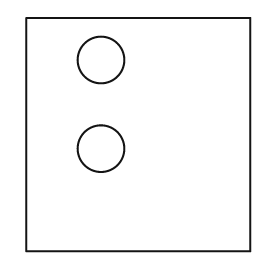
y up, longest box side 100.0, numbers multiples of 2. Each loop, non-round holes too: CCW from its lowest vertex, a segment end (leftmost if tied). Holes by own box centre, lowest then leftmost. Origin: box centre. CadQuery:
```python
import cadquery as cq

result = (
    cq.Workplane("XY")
    .moveTo(-48.0, -50.0)
    .lineTo(48.0, -50.0)
    .lineTo(48.0, 50.0)
    .lineTo(-48.0, 50.0)
    .close()
    .moveTo(-16.0, -6.0)
    .circle(10.0)
    .moveTo(-16.0, 32.0)
    .circle(10.0)
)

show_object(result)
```